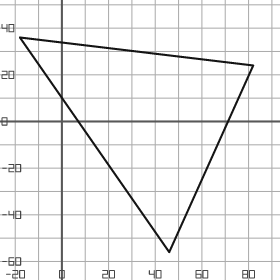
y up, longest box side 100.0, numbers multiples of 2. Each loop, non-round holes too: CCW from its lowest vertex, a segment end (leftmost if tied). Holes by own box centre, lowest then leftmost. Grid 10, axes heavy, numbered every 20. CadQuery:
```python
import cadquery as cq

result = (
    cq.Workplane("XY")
    .moveTo(46.0, -56.0)
    .lineTo(82.0, 24.0)
    .lineTo(-18.0, 36.0)
    .close()
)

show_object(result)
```